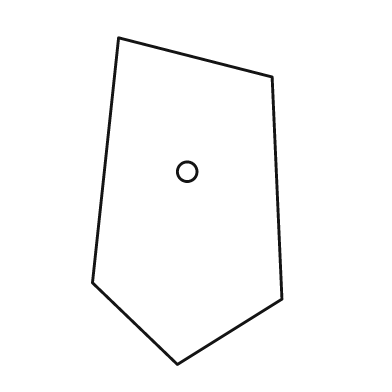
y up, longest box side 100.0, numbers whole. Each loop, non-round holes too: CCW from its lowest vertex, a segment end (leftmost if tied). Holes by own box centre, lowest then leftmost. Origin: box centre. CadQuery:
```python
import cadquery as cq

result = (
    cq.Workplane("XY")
    .moveTo(-3.0, -50.0)
    .lineTo(29.0, -30.0)
    .lineTo(26.0, 38.0)
    .lineTo(-21.0, 50.0)
    .lineTo(-29.0, -25.0)
    .close()
    .moveTo(0.0, 9.0)
    .circle(3.0)
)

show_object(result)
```